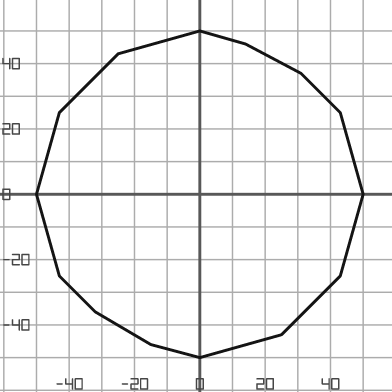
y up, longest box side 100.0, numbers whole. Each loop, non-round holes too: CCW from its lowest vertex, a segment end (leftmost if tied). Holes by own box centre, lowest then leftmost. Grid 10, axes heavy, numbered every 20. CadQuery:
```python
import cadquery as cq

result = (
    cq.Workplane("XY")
    .moveTo(0.0, -50.0)
    .lineTo(25.0, -43.0)
    .lineTo(43.0, -25.0)
    .lineTo(50.0, 0.0)
    .lineTo(43.0, 25.0)
    .lineTo(31.0, 37.0)
    .lineTo(14.0, 46.0)
    .lineTo(0.0, 50.0)
    .lineTo(-25.0, 43.0)
    .lineTo(-43.0, 25.0)
    .lineTo(-50.0, 0.0)
    .lineTo(-43.0, -25.0)
    .lineTo(-32.0, -36.0)
    .lineTo(-15.0, -46.0)
    .close()
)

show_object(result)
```